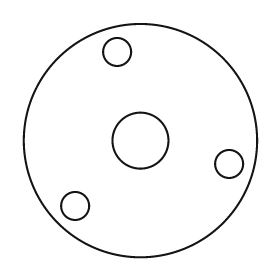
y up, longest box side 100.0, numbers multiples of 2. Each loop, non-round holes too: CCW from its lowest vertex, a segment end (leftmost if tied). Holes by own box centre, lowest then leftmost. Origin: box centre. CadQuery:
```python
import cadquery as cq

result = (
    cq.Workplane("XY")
    .moveTo(0.0, 0.0)
    .circle(50.0)
    .moveTo(-28.0, -28.0)
    .circle(6.0)
    .moveTo(38.0, -10.0)
    .circle(6.0)
    .moveTo(0.0, 0.0)
    .circle(12.0)
    .moveTo(-10.0, 38.0)
    .circle(6.0)
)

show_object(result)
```